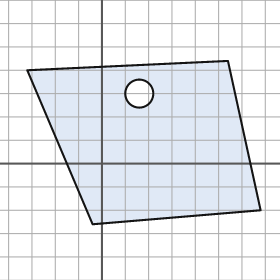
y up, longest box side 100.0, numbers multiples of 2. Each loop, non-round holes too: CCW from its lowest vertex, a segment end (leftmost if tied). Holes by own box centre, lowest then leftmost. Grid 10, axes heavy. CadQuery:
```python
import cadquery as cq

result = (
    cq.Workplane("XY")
    .moveTo(-4.0, -26.0)
    .lineTo(68.0, -20.0)
    .lineTo(54.0, 44.0)
    .lineTo(-32.0, 40.0)
    .close()
    .moveTo(16.0, 30.0)
    .circle(6.0)
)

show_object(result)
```